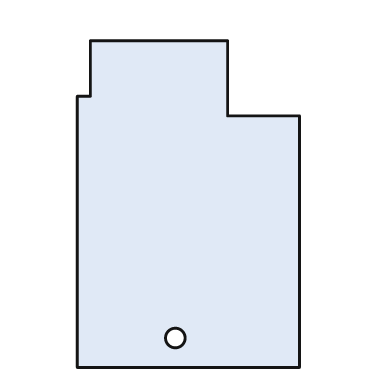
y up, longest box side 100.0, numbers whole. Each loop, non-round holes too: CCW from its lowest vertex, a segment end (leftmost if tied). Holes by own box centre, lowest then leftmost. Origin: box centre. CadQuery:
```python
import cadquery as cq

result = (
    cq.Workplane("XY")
    .moveTo(-34.0, -50.0)
    .lineTo(34.0, -50.0)
    .lineTo(34.0, 27.0)
    .lineTo(12.0, 27.0)
    .lineTo(12.0, 50.0)
    .lineTo(-30.0, 50.0)
    .lineTo(-30.0, 33.0)
    .lineTo(-34.0, 33.0)
    .close()
    .moveTo(-4.0, -41.0)
    .circle(3.0)
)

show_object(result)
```